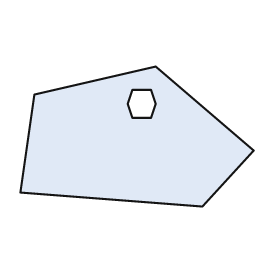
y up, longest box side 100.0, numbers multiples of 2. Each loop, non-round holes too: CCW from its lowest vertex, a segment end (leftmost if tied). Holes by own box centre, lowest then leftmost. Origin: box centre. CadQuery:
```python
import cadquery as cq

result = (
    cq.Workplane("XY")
    .moveTo(28.0, -30.0)
    .lineTo(50.0, -6.0)
    .lineTo(8.0, 30.0)
    .lineTo(-44.0, 18.0)
    .lineTo(-50.0, -24.0)
    .close()
    .moveTo(-2.0, 8.0)
    .lineTo(6.0, 8.0)
    .lineTo(8.0, 14.0)
    .lineTo(6.0, 20.0)
    .lineTo(-2.0, 20.0)
    .lineTo(-4.0, 14.0)
    .close()
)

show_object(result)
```